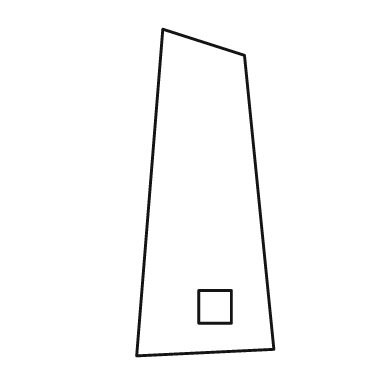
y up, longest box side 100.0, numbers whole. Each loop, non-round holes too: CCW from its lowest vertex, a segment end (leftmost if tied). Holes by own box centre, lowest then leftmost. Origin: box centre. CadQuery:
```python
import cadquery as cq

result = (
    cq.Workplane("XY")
    .moveTo(-21.0, -50.0)
    .lineTo(21.0, -48.0)
    .lineTo(12.0, 42.0)
    .lineTo(-13.0, 50.0)
    .close()
    .moveTo(-2.0, -40.0)
    .lineTo(8.0, -40.0)
    .lineTo(8.0, -30.0)
    .lineTo(-2.0, -30.0)
    .close()
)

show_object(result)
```